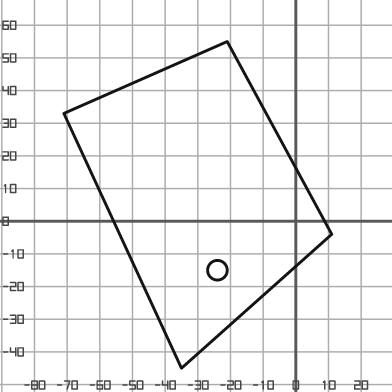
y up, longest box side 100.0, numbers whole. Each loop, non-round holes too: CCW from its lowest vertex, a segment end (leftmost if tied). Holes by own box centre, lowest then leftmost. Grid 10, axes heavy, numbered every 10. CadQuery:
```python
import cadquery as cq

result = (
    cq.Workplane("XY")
    .moveTo(-35.0, -45.0)
    .lineTo(11.0, -4.0)
    .lineTo(-21.0, 55.0)
    .lineTo(-71.0, 33.0)
    .close()
    .moveTo(-24.0, -15.0)
    .circle(3.0)
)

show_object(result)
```